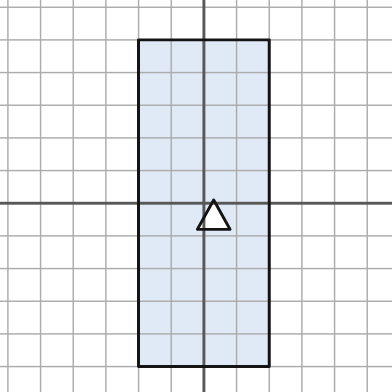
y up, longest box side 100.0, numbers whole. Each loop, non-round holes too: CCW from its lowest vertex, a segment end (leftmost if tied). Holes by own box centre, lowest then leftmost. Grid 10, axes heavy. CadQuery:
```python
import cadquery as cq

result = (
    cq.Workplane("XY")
    .moveTo(-20.0, -50.0)
    .lineTo(20.0, -50.0)
    .lineTo(20.0, 50.0)
    .lineTo(-20.0, 50.0)
    .close()
    .moveTo(-2.0, -8.0)
    .lineTo(8.0, -8.0)
    .lineTo(3.0, 1.0)
    .close()
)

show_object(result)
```